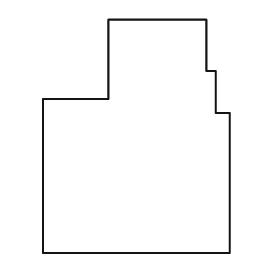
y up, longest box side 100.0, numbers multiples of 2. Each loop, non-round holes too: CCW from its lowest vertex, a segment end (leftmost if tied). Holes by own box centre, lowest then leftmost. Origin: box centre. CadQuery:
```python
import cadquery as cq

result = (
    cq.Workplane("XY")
    .moveTo(-40.0, -50.0)
    .lineTo(40.0, -50.0)
    .lineTo(40.0, 10.0)
    .lineTo(34.0, 10.0)
    .lineTo(34.0, 28.0)
    .lineTo(30.0, 28.0)
    .lineTo(30.0, 50.0)
    .lineTo(-12.0, 50.0)
    .lineTo(-12.0, 16.0)
    .lineTo(-40.0, 16.0)
    .close()
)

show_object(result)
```